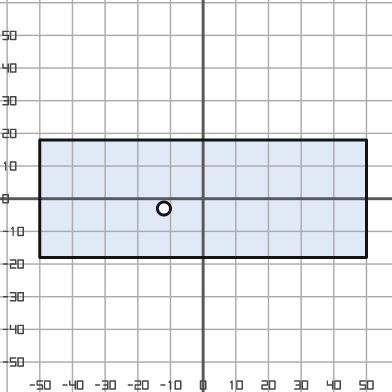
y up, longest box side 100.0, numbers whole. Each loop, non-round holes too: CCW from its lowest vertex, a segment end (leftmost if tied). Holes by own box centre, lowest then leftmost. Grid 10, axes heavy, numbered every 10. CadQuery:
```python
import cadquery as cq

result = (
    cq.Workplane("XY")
    .moveTo(-50.0, -18.0)
    .lineTo(50.0, -18.0)
    .lineTo(50.0, 18.0)
    .lineTo(-50.0, 18.0)
    .close()
    .moveTo(-12.0, -3.0)
    .circle(2.0)
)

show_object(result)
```